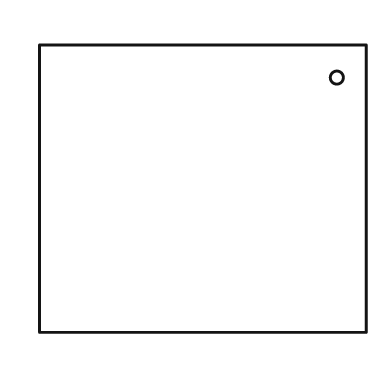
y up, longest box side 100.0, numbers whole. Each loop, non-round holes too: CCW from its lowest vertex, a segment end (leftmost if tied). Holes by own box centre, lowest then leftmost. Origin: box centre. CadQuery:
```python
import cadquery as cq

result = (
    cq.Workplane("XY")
    .moveTo(-50.0, -44.0)
    .lineTo(50.0, -44.0)
    .lineTo(50.0, 44.0)
    .lineTo(-50.0, 44.0)
    .close()
    .moveTo(41.0, 34.0)
    .circle(2.0)
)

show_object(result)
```